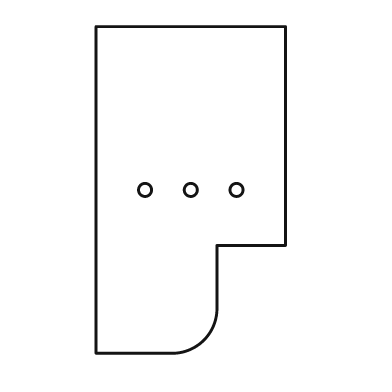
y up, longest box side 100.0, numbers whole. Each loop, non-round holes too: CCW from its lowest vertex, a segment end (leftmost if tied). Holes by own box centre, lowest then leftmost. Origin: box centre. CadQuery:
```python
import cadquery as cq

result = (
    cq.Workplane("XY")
    .moveTo(-29.0, -50.0)
    .lineTo(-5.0, -50.0)
    .threePointArc((4.0, -46.0), (8.0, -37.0))
    .lineTo(8.0, -17.0)
    .lineTo(29.0, -17.0)
    .lineTo(29.0, 50.0)
    .lineTo(-29.0, 50.0)
    .close()
    .moveTo(-14.0, 0.0)
    .circle(2.0)
    .moveTo(0.0, 0.0)
    .circle(2.0)
    .moveTo(14.0, 0.0)
    .circle(2.0)
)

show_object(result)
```